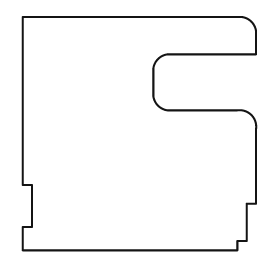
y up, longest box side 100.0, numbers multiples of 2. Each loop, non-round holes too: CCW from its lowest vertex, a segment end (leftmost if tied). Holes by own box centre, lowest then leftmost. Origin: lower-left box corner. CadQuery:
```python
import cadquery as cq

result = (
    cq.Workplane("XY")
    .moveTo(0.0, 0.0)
    .lineTo(92.0, 0.0)
    .lineTo(92.0, 4.0)
    .lineTo(96.0, 4.0)
    .lineTo(96.0, 20.0)
    .lineTo(100.0, 20.0)
    .lineTo(100.0, 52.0)
    .threePointArc((98.0, 58.0), (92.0, 60.0))
    .lineTo(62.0, 60.0)
    .threePointArc((58.0, 62.0), (56.0, 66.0))
    .lineTo(56.0, 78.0)
    .threePointArc((58.0, 82.0), (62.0, 84.0))
    .lineTo(100.0, 84.0)
    .lineTo(100.0, 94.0)
    .threePointArc((98.0, 98.0), (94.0, 100.0))
    .lineTo(0.0, 100.0)
    .lineTo(0.0, 28.0)
    .lineTo(4.0, 28.0)
    .lineTo(4.0, 10.0)
    .lineTo(0.0, 10.0)
    .close()
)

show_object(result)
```